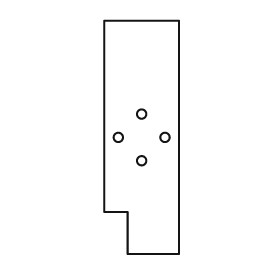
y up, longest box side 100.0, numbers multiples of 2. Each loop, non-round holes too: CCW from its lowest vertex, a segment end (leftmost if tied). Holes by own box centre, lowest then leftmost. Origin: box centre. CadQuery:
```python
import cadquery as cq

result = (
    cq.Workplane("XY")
    .moveTo(-6.0, -50.0)
    .lineTo(16.0, -50.0)
    .lineTo(16.0, 50.0)
    .lineTo(-16.0, 50.0)
    .lineTo(-16.0, -32.0)
    .lineTo(-6.0, -32.0)
    .close()
    .moveTo(0.0, -10.0)
    .circle(2.0)
    .moveTo(-10.0, 0.0)
    .circle(2.0)
    .moveTo(10.0, 0.0)
    .circle(2.0)
    .moveTo(0.0, 10.0)
    .circle(2.0)
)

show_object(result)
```